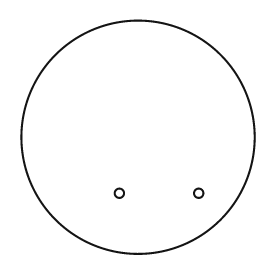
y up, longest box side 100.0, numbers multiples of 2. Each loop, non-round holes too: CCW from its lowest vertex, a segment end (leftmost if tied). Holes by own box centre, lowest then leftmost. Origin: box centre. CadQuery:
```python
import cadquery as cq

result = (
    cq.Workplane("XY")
    .moveTo(0.0, 0.0)
    .circle(50.0)
    .moveTo(-8.0, -24.0)
    .circle(2.0)
    .moveTo(26.0, -24.0)
    .circle(2.0)
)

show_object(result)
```